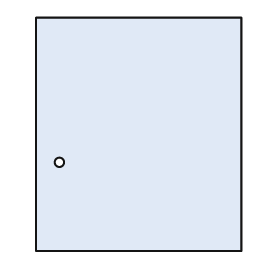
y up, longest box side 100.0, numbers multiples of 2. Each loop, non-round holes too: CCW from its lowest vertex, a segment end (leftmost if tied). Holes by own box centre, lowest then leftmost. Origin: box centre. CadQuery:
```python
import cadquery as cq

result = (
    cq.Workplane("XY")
    .moveTo(-44.0, -50.0)
    .lineTo(44.0, -50.0)
    .lineTo(44.0, 50.0)
    .lineTo(-44.0, 50.0)
    .close()
    .moveTo(-34.0, -12.0)
    .circle(2.0)
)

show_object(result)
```